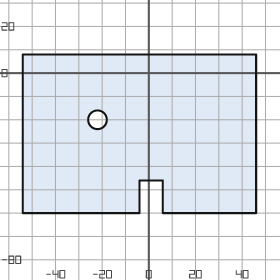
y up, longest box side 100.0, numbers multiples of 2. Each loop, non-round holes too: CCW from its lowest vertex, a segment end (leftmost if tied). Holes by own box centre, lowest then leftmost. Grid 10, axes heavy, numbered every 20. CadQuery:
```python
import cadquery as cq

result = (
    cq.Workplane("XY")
    .moveTo(-54.0, -60.0)
    .lineTo(-4.0, -60.0)
    .lineTo(-4.0, -46.0)
    .lineTo(6.0, -46.0)
    .lineTo(6.0, -60.0)
    .lineTo(46.0, -60.0)
    .lineTo(46.0, 8.0)
    .lineTo(-54.0, 8.0)
    .close()
    .moveTo(-22.0, -20.0)
    .circle(4.0)
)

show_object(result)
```